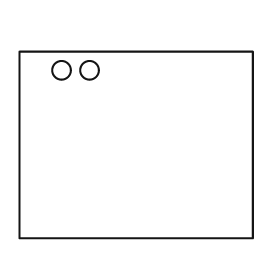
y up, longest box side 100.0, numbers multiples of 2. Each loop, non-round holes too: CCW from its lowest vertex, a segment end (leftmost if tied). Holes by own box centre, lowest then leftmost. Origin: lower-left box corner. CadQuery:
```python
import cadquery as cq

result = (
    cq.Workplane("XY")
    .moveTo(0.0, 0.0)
    .lineTo(100.0, 0.0)
    .lineTo(100.0, 80.0)
    .lineTo(0.0, 80.0)
    .close()
    .moveTo(18.0, 72.0)
    .circle(4.0)
    .moveTo(30.0, 72.0)
    .circle(4.0)
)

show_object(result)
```